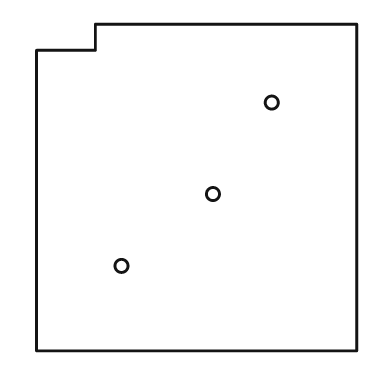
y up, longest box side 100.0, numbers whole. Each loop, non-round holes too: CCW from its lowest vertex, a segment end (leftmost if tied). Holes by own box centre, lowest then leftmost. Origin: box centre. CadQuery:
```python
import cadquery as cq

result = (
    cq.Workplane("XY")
    .moveTo(-49.0, -50.0)
    .lineTo(49.0, -50.0)
    .lineTo(49.0, 50.0)
    .lineTo(-31.0, 50.0)
    .lineTo(-31.0, 42.0)
    .lineTo(-49.0, 42.0)
    .close()
    .moveTo(-23.0, -24.0)
    .circle(2.0)
    .moveTo(5.0, -2.0)
    .circle(2.0)
    .moveTo(23.0, 26.0)
    .circle(2.0)
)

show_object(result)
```